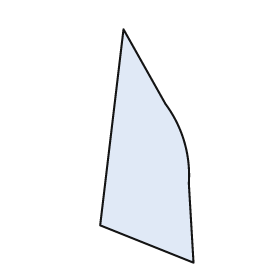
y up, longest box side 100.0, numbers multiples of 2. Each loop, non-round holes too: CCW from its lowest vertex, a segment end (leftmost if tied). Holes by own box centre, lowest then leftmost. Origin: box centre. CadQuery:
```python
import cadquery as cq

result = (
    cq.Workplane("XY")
    .moveTo(20.0, -50.0)
    .lineTo(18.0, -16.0)
    .threePointArc((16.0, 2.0), (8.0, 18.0))
    .lineTo(-10.0, 50.0)
    .lineTo(-20.0, -34.0)
    .close()
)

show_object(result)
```